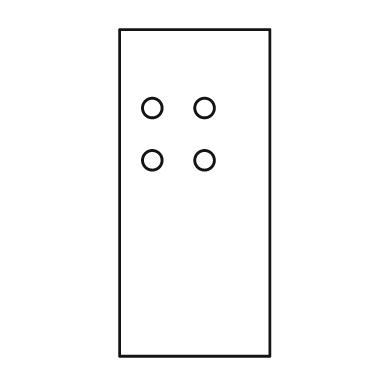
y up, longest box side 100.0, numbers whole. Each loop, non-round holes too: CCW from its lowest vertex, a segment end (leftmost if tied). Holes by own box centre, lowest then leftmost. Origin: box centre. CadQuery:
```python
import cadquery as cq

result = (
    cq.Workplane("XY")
    .moveTo(-23.0, -50.0)
    .lineTo(23.0, -50.0)
    .lineTo(23.0, 50.0)
    .lineTo(-23.0, 50.0)
    .close()
    .moveTo(-13.0, 10.0)
    .circle(3.0)
    .moveTo(3.0, 10.0)
    .circle(3.0)
    .moveTo(-13.0, 26.0)
    .circle(3.0)
    .moveTo(3.0, 26.0)
    .circle(3.0)
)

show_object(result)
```